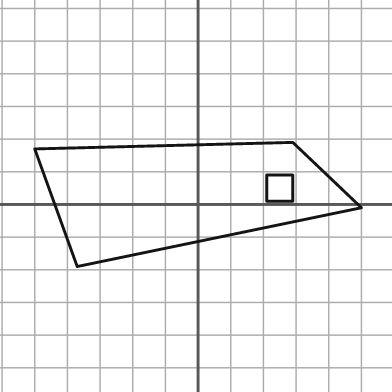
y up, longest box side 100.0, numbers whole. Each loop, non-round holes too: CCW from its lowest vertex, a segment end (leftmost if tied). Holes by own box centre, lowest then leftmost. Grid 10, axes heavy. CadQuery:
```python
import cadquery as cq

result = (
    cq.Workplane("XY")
    .moveTo(-37.0, -19.0)
    .lineTo(50.0, -1.0)
    .lineTo(29.0, 19.0)
    .lineTo(-50.0, 17.0)
    .close()
    .moveTo(21.0, 1.0)
    .lineTo(29.0, 1.0)
    .lineTo(29.0, 9.0)
    .lineTo(21.0, 9.0)
    .close()
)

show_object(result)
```